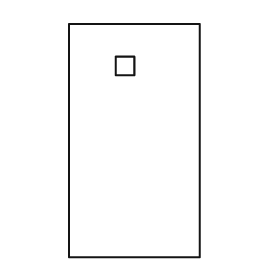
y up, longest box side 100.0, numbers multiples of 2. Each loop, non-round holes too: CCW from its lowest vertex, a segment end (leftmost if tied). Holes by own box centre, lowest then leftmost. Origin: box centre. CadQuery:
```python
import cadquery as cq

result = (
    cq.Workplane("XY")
    .moveTo(-28.0, -50.0)
    .lineTo(28.0, -50.0)
    .lineTo(28.0, 50.0)
    .lineTo(-28.0, 50.0)
    .close()
    .moveTo(-8.0, 28.0)
    .lineTo(0.0, 28.0)
    .lineTo(0.0, 36.0)
    .lineTo(-8.0, 36.0)
    .close()
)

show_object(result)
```